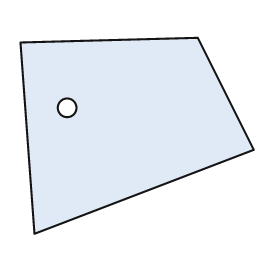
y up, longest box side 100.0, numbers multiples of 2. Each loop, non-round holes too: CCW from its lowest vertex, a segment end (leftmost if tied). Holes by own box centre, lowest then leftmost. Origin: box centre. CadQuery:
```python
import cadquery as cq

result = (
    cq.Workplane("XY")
    .moveTo(-44.0, -42.0)
    .lineTo(50.0, -6.0)
    .lineTo(26.0, 42.0)
    .lineTo(-50.0, 40.0)
    .close()
    .moveTo(-30.0, 12.0)
    .circle(4.0)
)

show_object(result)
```